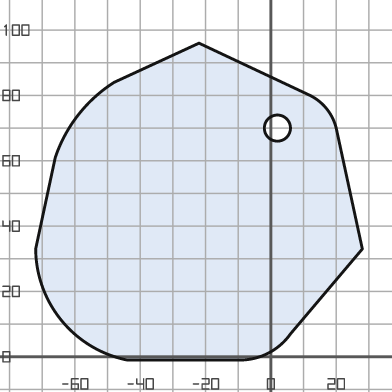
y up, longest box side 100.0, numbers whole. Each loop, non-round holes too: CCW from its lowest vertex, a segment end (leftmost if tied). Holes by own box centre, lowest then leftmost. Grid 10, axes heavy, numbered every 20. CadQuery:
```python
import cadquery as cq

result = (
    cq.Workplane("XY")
    .moveTo(-44.0, -1.0)
    .lineTo(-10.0, -1.0)
    .threePointArc((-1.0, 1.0), (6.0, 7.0))
    .lineTo(28.0, 33.0)
    .lineTo(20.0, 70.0)
    .threePointArc((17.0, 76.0), (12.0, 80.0))
    .lineTo(-22.0, 96.0)
    .lineTo(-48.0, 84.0)
    .threePointArc((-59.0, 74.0), (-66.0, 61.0))
    .lineTo(-72.0, 33.0)
    .threePointArc((-64.0, 11.0), (-44.0, -1.0))
    .close()
    .moveTo(2.0, 70.0)
    .circle(4.0)
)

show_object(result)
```